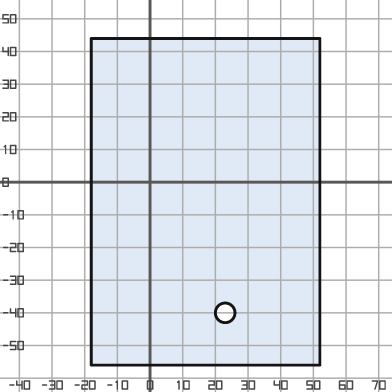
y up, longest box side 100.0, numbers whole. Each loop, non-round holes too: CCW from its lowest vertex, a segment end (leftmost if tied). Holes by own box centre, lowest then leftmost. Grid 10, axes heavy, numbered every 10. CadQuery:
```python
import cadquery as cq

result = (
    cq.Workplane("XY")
    .moveTo(-18.0, -56.0)
    .lineTo(52.0, -56.0)
    .lineTo(52.0, 44.0)
    .lineTo(-18.0, 44.0)
    .close()
    .moveTo(23.0, -40.0)
    .circle(3.0)
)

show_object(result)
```